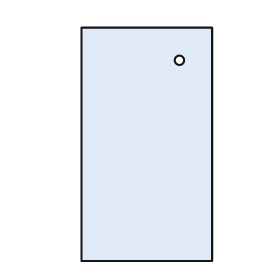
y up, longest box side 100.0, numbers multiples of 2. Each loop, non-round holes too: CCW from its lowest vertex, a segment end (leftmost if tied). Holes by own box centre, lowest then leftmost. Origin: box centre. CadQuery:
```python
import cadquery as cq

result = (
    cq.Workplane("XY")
    .moveTo(-28.0, -50.0)
    .lineTo(28.0, -50.0)
    .lineTo(28.0, 50.0)
    .lineTo(-28.0, 50.0)
    .close()
    .moveTo(14.0, 36.0)
    .circle(2.0)
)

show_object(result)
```